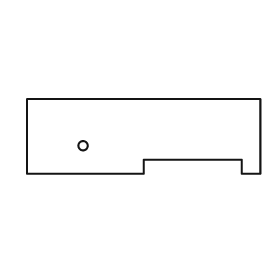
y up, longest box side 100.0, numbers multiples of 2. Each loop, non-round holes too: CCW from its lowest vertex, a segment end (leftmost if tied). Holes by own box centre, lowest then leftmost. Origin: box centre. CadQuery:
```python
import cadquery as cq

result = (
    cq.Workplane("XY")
    .moveTo(-50.0, -16.0)
    .lineTo(0.0, -16.0)
    .lineTo(0.0, -10.0)
    .lineTo(42.0, -10.0)
    .lineTo(42.0, -16.0)
    .lineTo(50.0, -16.0)
    .lineTo(50.0, 16.0)
    .lineTo(-50.0, 16.0)
    .close()
    .moveTo(-26.0, -4.0)
    .circle(2.0)
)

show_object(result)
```